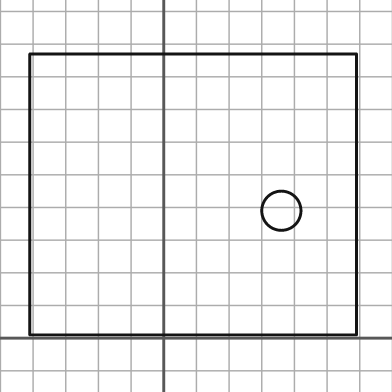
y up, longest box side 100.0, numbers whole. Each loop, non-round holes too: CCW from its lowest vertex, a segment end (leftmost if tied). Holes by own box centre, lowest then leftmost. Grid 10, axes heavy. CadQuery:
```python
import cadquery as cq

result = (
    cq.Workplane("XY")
    .moveTo(-41.0, 1.0)
    .lineTo(59.0, 1.0)
    .lineTo(59.0, 87.0)
    .lineTo(-41.0, 87.0)
    .close()
    .moveTo(36.0, 39.0)
    .circle(6.0)
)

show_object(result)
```